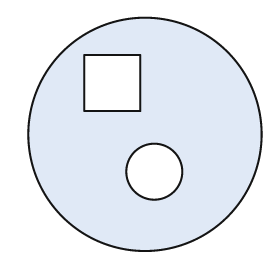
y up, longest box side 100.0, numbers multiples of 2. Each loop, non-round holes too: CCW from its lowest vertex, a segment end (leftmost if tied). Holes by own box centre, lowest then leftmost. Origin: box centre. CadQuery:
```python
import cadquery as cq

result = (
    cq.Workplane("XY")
    .moveTo(0.0, 0.0)
    .circle(50.0)
    .moveTo(4.0, -16.0)
    .circle(12.0)
    .moveTo(-26.0, 10.0)
    .lineTo(-2.0, 10.0)
    .lineTo(-2.0, 34.0)
    .lineTo(-26.0, 34.0)
    .close()
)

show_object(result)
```